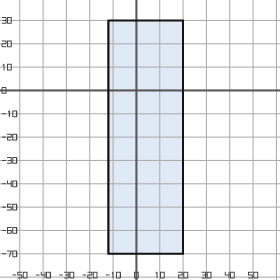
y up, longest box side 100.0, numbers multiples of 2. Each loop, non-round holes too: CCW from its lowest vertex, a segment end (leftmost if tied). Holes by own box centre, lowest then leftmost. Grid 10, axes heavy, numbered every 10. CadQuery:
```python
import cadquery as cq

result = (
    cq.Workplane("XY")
    .moveTo(-12.0, -70.0)
    .lineTo(20.0, -70.0)
    .lineTo(20.0, 30.0)
    .lineTo(-12.0, 30.0)
    .close()
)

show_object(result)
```